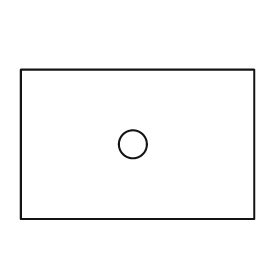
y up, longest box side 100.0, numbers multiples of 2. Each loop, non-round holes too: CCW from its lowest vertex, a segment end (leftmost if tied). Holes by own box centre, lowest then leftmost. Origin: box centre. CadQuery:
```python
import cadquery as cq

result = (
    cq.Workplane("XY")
    .moveTo(-50.0, -32.0)
    .lineTo(50.0, -32.0)
    .lineTo(50.0, 32.0)
    .lineTo(-50.0, 32.0)
    .close()
    .moveTo(-2.0, 0.0)
    .circle(6.0)
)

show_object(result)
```